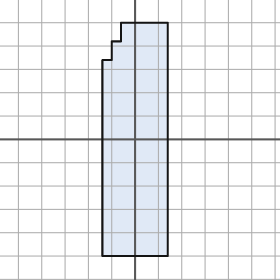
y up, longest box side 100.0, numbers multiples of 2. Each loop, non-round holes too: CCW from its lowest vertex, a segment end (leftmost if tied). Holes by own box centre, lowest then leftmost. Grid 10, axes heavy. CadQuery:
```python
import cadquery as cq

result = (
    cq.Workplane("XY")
    .moveTo(-14.0, -50.0)
    .lineTo(14.0, -50.0)
    .lineTo(14.0, 50.0)
    .lineTo(-6.0, 50.0)
    .lineTo(-6.0, 42.0)
    .lineTo(-10.0, 42.0)
    .lineTo(-10.0, 34.0)
    .lineTo(-14.0, 34.0)
    .close()
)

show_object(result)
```